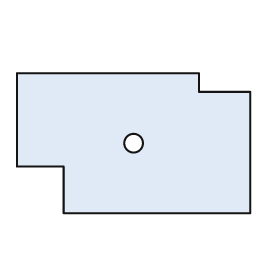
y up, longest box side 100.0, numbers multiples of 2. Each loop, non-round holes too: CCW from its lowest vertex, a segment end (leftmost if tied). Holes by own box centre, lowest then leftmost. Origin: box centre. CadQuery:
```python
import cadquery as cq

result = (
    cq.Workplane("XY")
    .moveTo(-30.0, -30.0)
    .lineTo(50.0, -30.0)
    .lineTo(50.0, 22.0)
    .lineTo(28.0, 22.0)
    .lineTo(28.0, 30.0)
    .lineTo(-50.0, 30.0)
    .lineTo(-50.0, -10.0)
    .lineTo(-30.0, -10.0)
    .close()
    .moveTo(0.0, 0.0)
    .circle(4.0)
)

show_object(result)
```